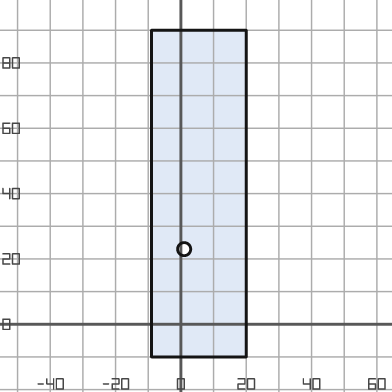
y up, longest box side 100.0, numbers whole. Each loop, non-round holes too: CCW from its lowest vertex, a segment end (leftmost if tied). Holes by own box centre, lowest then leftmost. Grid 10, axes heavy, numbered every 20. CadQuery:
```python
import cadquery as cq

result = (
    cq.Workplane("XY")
    .moveTo(-9.0, -10.0)
    .lineTo(20.0, -10.0)
    .lineTo(20.0, 90.0)
    .lineTo(-9.0, 90.0)
    .close()
    .moveTo(1.0, 23.0)
    .circle(2.0)
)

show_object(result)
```